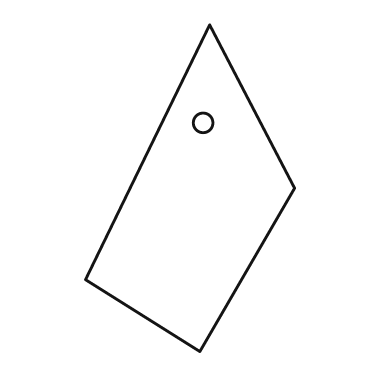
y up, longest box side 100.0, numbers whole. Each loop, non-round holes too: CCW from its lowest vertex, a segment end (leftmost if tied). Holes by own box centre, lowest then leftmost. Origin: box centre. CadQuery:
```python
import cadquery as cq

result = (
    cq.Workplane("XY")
    .moveTo(3.0, -50.0)
    .lineTo(32.0, 0.0)
    .lineTo(6.0, 50.0)
    .lineTo(-32.0, -28.0)
    .close()
    .moveTo(4.0, 20.0)
    .circle(3.0)
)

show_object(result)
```